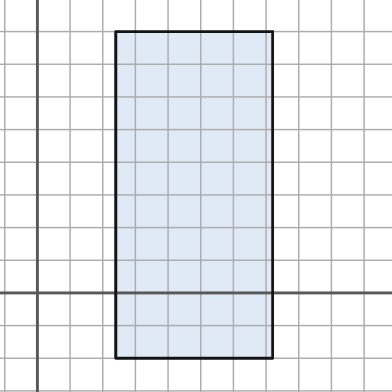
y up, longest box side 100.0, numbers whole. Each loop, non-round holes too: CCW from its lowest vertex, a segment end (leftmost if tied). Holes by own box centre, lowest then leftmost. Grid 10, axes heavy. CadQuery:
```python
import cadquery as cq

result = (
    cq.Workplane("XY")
    .moveTo(24.0, -20.0)
    .lineTo(72.0, -20.0)
    .lineTo(72.0, 80.0)
    .lineTo(24.0, 80.0)
    .close()
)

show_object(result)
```